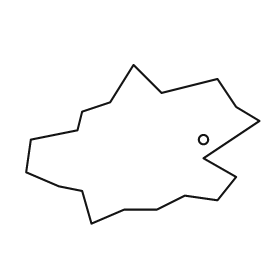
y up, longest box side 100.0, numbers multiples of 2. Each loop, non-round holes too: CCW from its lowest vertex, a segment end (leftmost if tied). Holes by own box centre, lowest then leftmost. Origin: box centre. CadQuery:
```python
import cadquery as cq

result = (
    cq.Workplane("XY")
    .moveTo(-22.0, -34.0)
    .lineTo(-8.0, -28.0)
    .lineTo(6.0, -28.0)
    .lineTo(18.0, -22.0)
    .lineTo(32.0, -24.0)
    .lineTo(40.0, -14.0)
    .lineTo(26.0, -6.0)
    .lineTo(50.0, 10.0)
    .lineTo(40.0, 16.0)
    .lineTo(32.0, 28.0)
    .lineTo(8.0, 22.0)
    .lineTo(-4.0, 34.0)
    .lineTo(-14.0, 18.0)
    .lineTo(-26.0, 14.0)
    .lineTo(-28.0, 6.0)
    .lineTo(-48.0, 2.0)
    .lineTo(-50.0, -12.0)
    .lineTo(-36.0, -18.0)
    .lineTo(-26.0, -20.0)
    .close()
    .moveTo(26.0, 2.0)
    .circle(2.0)
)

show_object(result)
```